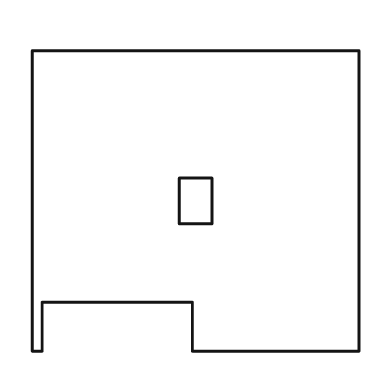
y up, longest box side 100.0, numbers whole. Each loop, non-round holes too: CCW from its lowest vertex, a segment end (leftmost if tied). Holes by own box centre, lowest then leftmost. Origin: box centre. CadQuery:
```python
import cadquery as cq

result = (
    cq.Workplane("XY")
    .moveTo(-50.0, -46.0)
    .lineTo(-47.0, -46.0)
    .lineTo(-47.0, -31.0)
    .lineTo(-1.0, -31.0)
    .lineTo(-1.0, -46.0)
    .lineTo(50.0, -46.0)
    .lineTo(50.0, 46.0)
    .lineTo(-50.0, 46.0)
    .close()
    .moveTo(-5.0, -7.0)
    .lineTo(5.0, -7.0)
    .lineTo(5.0, 7.0)
    .lineTo(-5.0, 7.0)
    .close()
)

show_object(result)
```